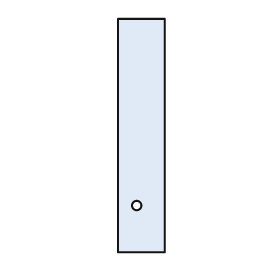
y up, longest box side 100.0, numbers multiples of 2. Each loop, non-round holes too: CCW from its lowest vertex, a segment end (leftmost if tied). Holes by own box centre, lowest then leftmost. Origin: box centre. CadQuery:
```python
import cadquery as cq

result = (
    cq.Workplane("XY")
    .moveTo(-10.0, -50.0)
    .lineTo(10.0, -50.0)
    .lineTo(10.0, 50.0)
    .lineTo(-10.0, 50.0)
    .close()
    .moveTo(-2.0, -30.0)
    .circle(2.0)
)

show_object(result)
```